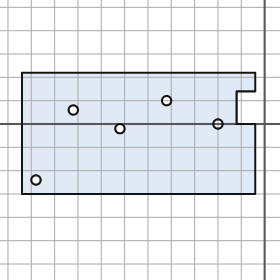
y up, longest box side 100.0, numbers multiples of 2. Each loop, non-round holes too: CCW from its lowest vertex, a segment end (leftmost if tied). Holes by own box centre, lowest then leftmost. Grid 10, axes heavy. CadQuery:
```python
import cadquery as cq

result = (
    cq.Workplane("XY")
    .moveTo(-104.0, -30.0)
    .lineTo(-4.0, -30.0)
    .lineTo(-4.0, 0.0)
    .lineTo(-12.0, 0.0)
    .lineTo(-12.0, 14.0)
    .lineTo(-4.0, 14.0)
    .lineTo(-4.0, 22.0)
    .lineTo(-104.0, 22.0)
    .close()
    .moveTo(-98.0, -24.0)
    .circle(2.0)
    .moveTo(-62.0, -2.0)
    .circle(2.0)
    .moveTo(-20.0, 0.0)
    .circle(2.0)
    .moveTo(-82.0, 6.0)
    .circle(2.0)
    .moveTo(-42.0, 10.0)
    .circle(2.0)
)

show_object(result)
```